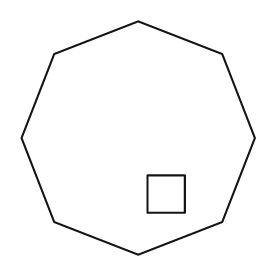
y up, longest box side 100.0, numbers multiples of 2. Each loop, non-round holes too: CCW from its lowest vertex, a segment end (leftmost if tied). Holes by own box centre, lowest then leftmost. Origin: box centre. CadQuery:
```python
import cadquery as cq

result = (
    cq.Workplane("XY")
    .moveTo(0.0, -50.0)
    .lineTo(36.0, -36.0)
    .lineTo(50.0, 0.0)
    .lineTo(36.0, 36.0)
    .lineTo(0.0, 50.0)
    .lineTo(-36.0, 36.0)
    .lineTo(-50.0, 0.0)
    .lineTo(-36.0, -36.0)
    .close()
    .moveTo(4.0, -32.0)
    .lineTo(20.0, -32.0)
    .lineTo(20.0, -16.0)
    .lineTo(4.0, -16.0)
    .close()
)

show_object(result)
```